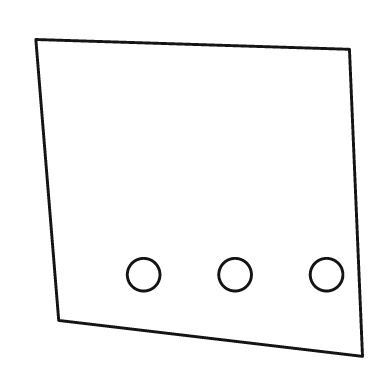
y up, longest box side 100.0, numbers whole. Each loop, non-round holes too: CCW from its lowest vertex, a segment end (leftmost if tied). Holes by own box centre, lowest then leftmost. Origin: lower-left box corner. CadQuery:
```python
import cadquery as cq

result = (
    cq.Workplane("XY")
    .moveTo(100.0, 0.0)
    .lineTo(96.0, 94.0)
    .lineTo(0.0, 97.0)
    .lineTo(7.0, 11.0)
    .close()
    .moveTo(33.0, 25.0)
    .circle(5.0)
    .moveTo(61.0, 25.0)
    .circle(5.0)
    .moveTo(89.0, 25.0)
    .circle(5.0)
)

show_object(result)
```